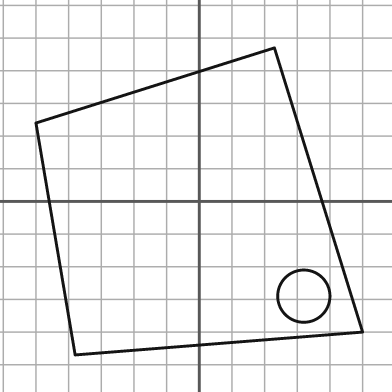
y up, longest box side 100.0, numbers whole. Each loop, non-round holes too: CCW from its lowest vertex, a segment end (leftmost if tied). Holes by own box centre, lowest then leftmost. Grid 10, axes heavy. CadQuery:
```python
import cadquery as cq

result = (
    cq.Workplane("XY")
    .moveTo(-38.0, -47.0)
    .lineTo(50.0, -40.0)
    .lineTo(23.0, 47.0)
    .lineTo(-50.0, 24.0)
    .close()
    .moveTo(32.0, -29.0)
    .circle(8.0)
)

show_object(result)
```